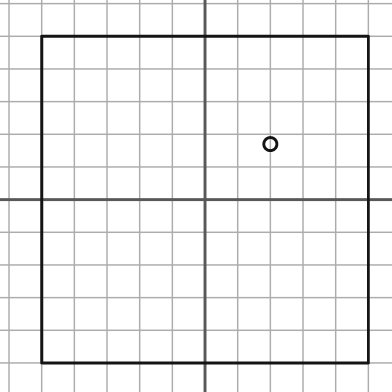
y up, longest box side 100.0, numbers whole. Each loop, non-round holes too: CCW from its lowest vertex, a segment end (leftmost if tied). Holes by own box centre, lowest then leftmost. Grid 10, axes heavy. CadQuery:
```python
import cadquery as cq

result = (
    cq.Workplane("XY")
    .moveTo(-50.0, -50.0)
    .lineTo(50.0, -50.0)
    .lineTo(50.0, 50.0)
    .lineTo(-50.0, 50.0)
    .close()
    .moveTo(20.0, 17.0)
    .circle(2.0)
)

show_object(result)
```